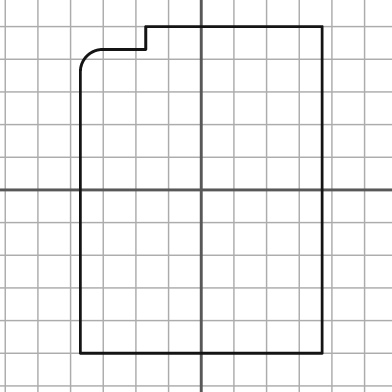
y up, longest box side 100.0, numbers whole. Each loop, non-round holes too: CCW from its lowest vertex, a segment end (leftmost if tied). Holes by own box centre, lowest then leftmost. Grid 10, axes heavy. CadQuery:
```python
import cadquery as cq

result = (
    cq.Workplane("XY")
    .moveTo(-37.0, -50.0)
    .lineTo(37.0, -50.0)
    .lineTo(37.0, 50.0)
    .lineTo(-17.0, 50.0)
    .lineTo(-17.0, 43.0)
    .lineTo(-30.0, 43.0)
    .threePointArc((-35.0, 41.0), (-37.0, 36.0))
    .close()
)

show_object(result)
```